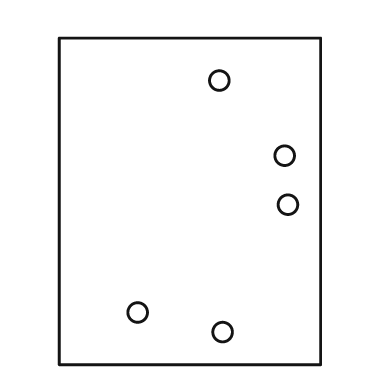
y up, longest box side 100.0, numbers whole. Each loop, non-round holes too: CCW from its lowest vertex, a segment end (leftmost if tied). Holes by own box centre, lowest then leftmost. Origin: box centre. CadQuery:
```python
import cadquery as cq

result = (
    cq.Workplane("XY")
    .moveTo(-40.0, -50.0)
    .lineTo(40.0, -50.0)
    .lineTo(40.0, 50.0)
    .lineTo(-40.0, 50.0)
    .close()
    .moveTo(10.0, -40.0)
    .circle(3.0)
    .moveTo(-16.0, -34.0)
    .circle(3.0)
    .moveTo(30.0, -1.0)
    .circle(3.0)
    .moveTo(29.0, 14.0)
    .circle(3.0)
    .moveTo(9.0, 37.0)
    .circle(3.0)
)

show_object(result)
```